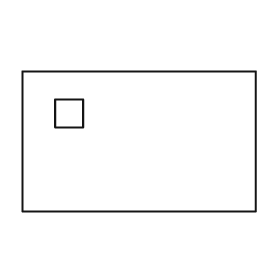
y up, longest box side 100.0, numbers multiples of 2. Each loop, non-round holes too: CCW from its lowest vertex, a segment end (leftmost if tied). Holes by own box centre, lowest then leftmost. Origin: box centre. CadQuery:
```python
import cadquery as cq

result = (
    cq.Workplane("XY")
    .moveTo(-50.0, -30.0)
    .lineTo(50.0, -30.0)
    .lineTo(50.0, 30.0)
    .lineTo(-50.0, 30.0)
    .close()
    .moveTo(-36.0, 6.0)
    .lineTo(-24.0, 6.0)
    .lineTo(-24.0, 18.0)
    .lineTo(-36.0, 18.0)
    .close()
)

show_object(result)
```